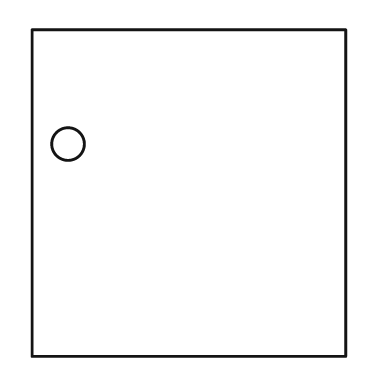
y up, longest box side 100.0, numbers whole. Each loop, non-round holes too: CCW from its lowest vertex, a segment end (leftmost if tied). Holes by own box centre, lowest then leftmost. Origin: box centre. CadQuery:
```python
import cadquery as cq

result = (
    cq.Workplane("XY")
    .moveTo(-48.0, -50.0)
    .lineTo(48.0, -50.0)
    .lineTo(48.0, 50.0)
    .lineTo(-48.0, 50.0)
    .close()
    .moveTo(-37.0, 15.0)
    .circle(5.0)
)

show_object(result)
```